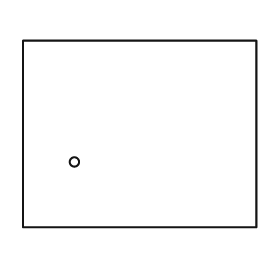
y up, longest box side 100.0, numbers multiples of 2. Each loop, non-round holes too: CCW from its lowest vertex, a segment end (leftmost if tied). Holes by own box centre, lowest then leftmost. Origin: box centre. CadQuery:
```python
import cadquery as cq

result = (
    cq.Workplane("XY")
    .moveTo(-50.0, -40.0)
    .lineTo(50.0, -40.0)
    .lineTo(50.0, 40.0)
    .lineTo(-50.0, 40.0)
    .close()
    .moveTo(-28.0, -12.0)
    .circle(2.0)
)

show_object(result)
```